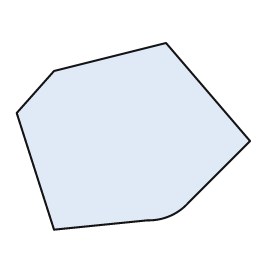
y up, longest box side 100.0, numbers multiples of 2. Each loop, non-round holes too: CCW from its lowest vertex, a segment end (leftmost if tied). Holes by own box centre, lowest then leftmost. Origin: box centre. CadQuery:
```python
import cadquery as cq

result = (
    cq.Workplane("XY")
    .moveTo(-34.0, -40.0)
    .lineTo(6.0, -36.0)
    .threePointArc((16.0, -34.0), (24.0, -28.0))
    .lineTo(50.0, -2.0)
    .lineTo(14.0, 40.0)
    .lineTo(-34.0, 28.0)
    .lineTo(-50.0, 10.0)
    .close()
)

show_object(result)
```